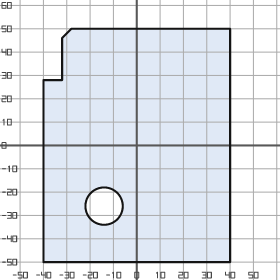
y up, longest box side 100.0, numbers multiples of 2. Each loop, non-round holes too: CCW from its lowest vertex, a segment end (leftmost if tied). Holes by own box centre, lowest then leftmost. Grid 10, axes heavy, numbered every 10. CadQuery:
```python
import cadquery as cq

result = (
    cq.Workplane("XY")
    .moveTo(-40.0, -50.0)
    .lineTo(40.0, -50.0)
    .lineTo(40.0, 50.0)
    .lineTo(-28.0, 50.0)
    .lineTo(-32.0, 46.0)
    .lineTo(-32.0, 28.0)
    .lineTo(-40.0, 28.0)
    .close()
    .moveTo(-14.0, -26.0)
    .circle(8.0)
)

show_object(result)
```